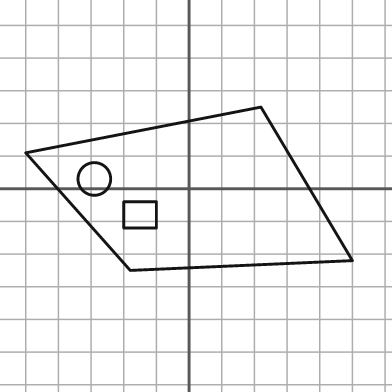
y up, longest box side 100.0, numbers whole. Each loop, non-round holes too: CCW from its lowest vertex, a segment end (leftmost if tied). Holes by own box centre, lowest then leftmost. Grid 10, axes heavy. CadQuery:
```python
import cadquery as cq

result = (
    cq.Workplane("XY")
    .moveTo(-18.0, -25.0)
    .lineTo(50.0, -22.0)
    .lineTo(22.0, 25.0)
    .lineTo(-50.0, 11.0)
    .close()
    .moveTo(-20.0, -12.0)
    .lineTo(-10.0, -12.0)
    .lineTo(-10.0, -4.0)
    .lineTo(-20.0, -4.0)
    .close()
    .moveTo(-29.0, 3.0)
    .circle(5.0)
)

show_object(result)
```